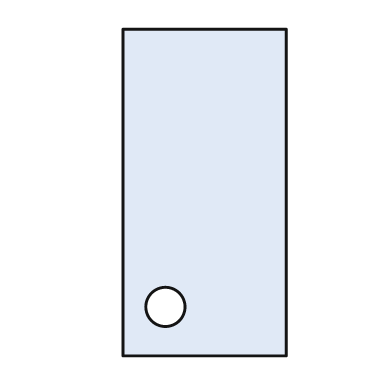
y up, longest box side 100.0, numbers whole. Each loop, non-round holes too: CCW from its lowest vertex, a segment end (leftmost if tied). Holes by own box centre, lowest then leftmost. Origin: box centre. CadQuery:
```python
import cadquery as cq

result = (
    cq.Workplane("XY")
    .moveTo(-25.0, -50.0)
    .lineTo(25.0, -50.0)
    .lineTo(25.0, 50.0)
    .lineTo(-25.0, 50.0)
    .close()
    .moveTo(-12.0, -35.0)
    .circle(6.0)
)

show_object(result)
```